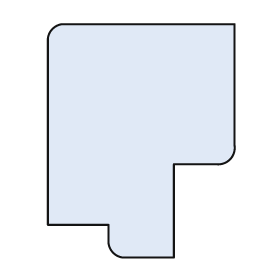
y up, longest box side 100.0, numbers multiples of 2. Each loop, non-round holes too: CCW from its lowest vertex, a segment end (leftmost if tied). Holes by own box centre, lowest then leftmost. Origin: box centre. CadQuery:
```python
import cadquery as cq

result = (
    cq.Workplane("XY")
    .moveTo(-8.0, -50.0)
    .lineTo(14.0, -50.0)
    .lineTo(14.0, -10.0)
    .lineTo(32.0, -10.0)
    .threePointArc((38.0, -8.0), (40.0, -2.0))
    .lineTo(40.0, 50.0)
    .lineTo(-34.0, 50.0)
    .threePointArc((-38.0, 48.0), (-40.0, 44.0))
    .lineTo(-40.0, -36.0)
    .lineTo(-14.0, -36.0)
    .lineTo(-14.0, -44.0)
    .threePointArc((-12.0, -48.0), (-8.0, -50.0))
    .close()
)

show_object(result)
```